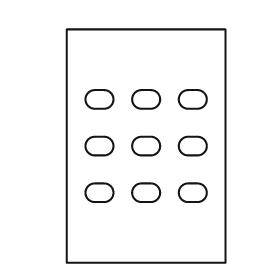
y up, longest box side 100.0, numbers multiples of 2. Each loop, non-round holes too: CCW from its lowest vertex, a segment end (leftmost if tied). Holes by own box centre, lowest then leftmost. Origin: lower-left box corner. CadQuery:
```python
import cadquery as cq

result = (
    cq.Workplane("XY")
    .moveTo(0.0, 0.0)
    .lineTo(68.0, 0.0)
    .lineTo(68.0, 100.0)
    .lineTo(0.0, 100.0)
    .close()
    .moveTo(12.0, 26.0)
    .lineTo(16.0, 26.0)
    .threePointArc((20.0, 30.0), (16.0, 34.0))
    .lineTo(12.0, 34.0)
    .threePointArc((8.0, 30.0), (12.0, 26.0))
    .close()
    .moveTo(32.0, 26.0)
    .lineTo(36.0, 26.0)
    .threePointArc((40.0, 30.0), (36.0, 34.0))
    .lineTo(32.0, 34.0)
    .threePointArc((28.0, 30.0), (32.0, 26.0))
    .close()
    .moveTo(52.0, 26.0)
    .lineTo(56.0, 26.0)
    .threePointArc((60.0, 30.0), (56.0, 34.0))
    .lineTo(52.0, 34.0)
    .threePointArc((48.0, 30.0), (52.0, 26.0))
    .close()
    .moveTo(12.0, 46.0)
    .lineTo(16.0, 46.0)
    .threePointArc((20.0, 50.0), (16.0, 54.0))
    .lineTo(12.0, 54.0)
    .threePointArc((8.0, 50.0), (12.0, 46.0))
    .close()
    .moveTo(32.0, 46.0)
    .lineTo(36.0, 46.0)
    .threePointArc((40.0, 50.0), (36.0, 54.0))
    .lineTo(32.0, 54.0)
    .threePointArc((28.0, 50.0), (32.0, 46.0))
    .close()
    .moveTo(52.0, 46.0)
    .lineTo(56.0, 46.0)
    .threePointArc((60.0, 50.0), (56.0, 54.0))
    .lineTo(52.0, 54.0)
    .threePointArc((48.0, 50.0), (52.0, 46.0))
    .close()
    .moveTo(12.0, 66.0)
    .lineTo(16.0, 66.0)
    .threePointArc((20.0, 70.0), (16.0, 74.0))
    .lineTo(12.0, 74.0)
    .threePointArc((8.0, 70.0), (12.0, 66.0))
    .close()
    .moveTo(32.0, 66.0)
    .lineTo(36.0, 66.0)
    .threePointArc((40.0, 70.0), (36.0, 74.0))
    .lineTo(32.0, 74.0)
    .threePointArc((28.0, 70.0), (32.0, 66.0))
    .close()
    .moveTo(52.0, 66.0)
    .lineTo(56.0, 66.0)
    .threePointArc((60.0, 70.0), (56.0, 74.0))
    .lineTo(52.0, 74.0)
    .threePointArc((48.0, 70.0), (52.0, 66.0))
    .close()
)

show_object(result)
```